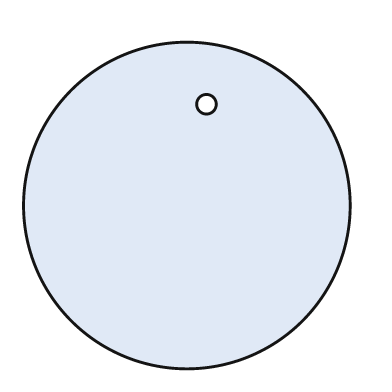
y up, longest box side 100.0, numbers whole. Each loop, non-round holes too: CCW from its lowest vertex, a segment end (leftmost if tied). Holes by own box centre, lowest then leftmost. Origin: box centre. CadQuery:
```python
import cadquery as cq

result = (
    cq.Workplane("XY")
    .moveTo(0.0, 0.0)
    .circle(50.0)
    .moveTo(6.0, 31.0)
    .circle(3.0)
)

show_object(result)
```